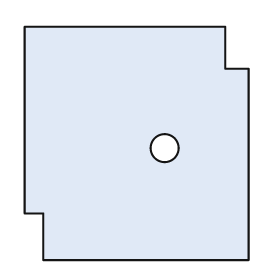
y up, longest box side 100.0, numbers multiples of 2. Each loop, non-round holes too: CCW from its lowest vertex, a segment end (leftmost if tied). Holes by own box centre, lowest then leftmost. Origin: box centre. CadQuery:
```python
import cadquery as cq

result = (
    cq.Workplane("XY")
    .moveTo(-40.0, -50.0)
    .lineTo(48.0, -50.0)
    .lineTo(48.0, 32.0)
    .lineTo(38.0, 32.0)
    .lineTo(38.0, 50.0)
    .lineTo(-48.0, 50.0)
    .lineTo(-48.0, -30.0)
    .lineTo(-40.0, -30.0)
    .close()
    .moveTo(12.0, -2.0)
    .circle(6.0)
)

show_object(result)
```